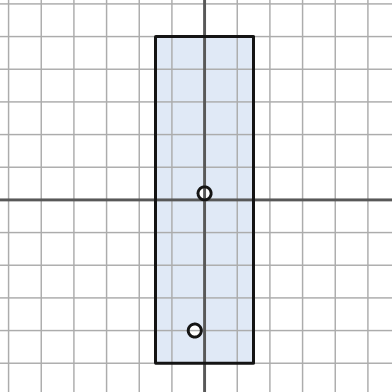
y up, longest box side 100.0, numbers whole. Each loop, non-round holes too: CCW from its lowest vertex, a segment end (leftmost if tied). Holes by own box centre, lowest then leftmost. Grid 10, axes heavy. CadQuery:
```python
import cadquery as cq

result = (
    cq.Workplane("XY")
    .moveTo(-15.0, -50.0)
    .lineTo(15.0, -50.0)
    .lineTo(15.0, 50.0)
    .lineTo(-15.0, 50.0)
    .close()
    .moveTo(-3.0, -40.0)
    .circle(2.0)
    .moveTo(0.0, 2.0)
    .circle(2.0)
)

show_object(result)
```